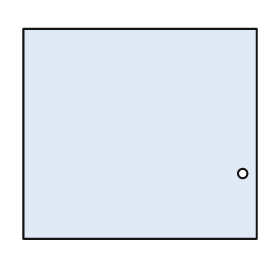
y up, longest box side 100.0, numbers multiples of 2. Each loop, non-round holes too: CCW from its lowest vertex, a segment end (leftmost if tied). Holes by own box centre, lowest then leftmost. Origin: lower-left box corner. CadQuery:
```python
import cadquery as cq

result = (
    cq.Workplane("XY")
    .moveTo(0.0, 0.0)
    .lineTo(100.0, 0.0)
    .lineTo(100.0, 90.0)
    .lineTo(0.0, 90.0)
    .close()
    .moveTo(94.0, 28.0)
    .circle(2.0)
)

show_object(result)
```